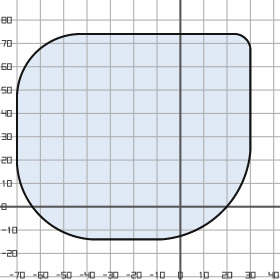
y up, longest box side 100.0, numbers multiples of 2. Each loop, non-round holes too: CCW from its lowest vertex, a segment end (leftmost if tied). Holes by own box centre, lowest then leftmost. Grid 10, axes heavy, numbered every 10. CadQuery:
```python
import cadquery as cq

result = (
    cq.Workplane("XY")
    .moveTo(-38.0, -14.0)
    .lineTo(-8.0, -14.0)
    .threePointArc((18.0, -2.0), (30.0, 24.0))
    .lineTo(30.0, 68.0)
    .threePointArc((28.0, 72.0), (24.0, 74.0))
    .lineTo(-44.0, 74.0)
    .threePointArc((-62.0, 66.0), (-70.0, 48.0))
    .lineTo(-70.0, 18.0)
    .threePointArc((-60.0, -4.0), (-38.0, -14.0))
    .close()
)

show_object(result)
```